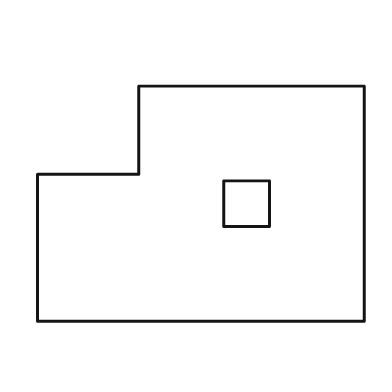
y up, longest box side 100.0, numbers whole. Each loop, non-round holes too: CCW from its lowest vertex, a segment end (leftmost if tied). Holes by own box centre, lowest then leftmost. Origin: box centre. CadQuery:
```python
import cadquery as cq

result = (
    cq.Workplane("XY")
    .moveTo(-50.0, -36.0)
    .lineTo(50.0, -36.0)
    .lineTo(50.0, 36.0)
    .lineTo(-19.0, 36.0)
    .lineTo(-19.0, 9.0)
    .lineTo(-50.0, 9.0)
    .close()
    .moveTo(7.0, -7.0)
    .lineTo(21.0, -7.0)
    .lineTo(21.0, 7.0)
    .lineTo(7.0, 7.0)
    .close()
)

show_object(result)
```